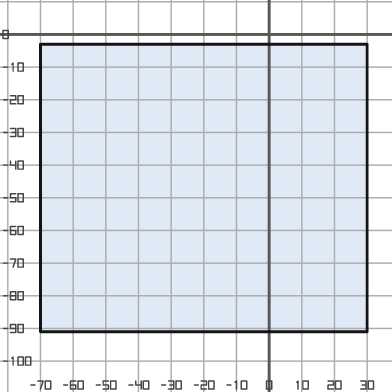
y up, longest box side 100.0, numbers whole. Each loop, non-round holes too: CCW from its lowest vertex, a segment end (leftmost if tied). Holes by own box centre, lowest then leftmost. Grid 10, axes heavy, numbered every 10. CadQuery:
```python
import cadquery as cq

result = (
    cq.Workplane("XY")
    .moveTo(-70.0, -91.0)
    .lineTo(30.0, -91.0)
    .lineTo(30.0, -3.0)
    .lineTo(-70.0, -3.0)
    .close()
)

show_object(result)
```